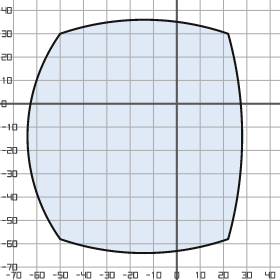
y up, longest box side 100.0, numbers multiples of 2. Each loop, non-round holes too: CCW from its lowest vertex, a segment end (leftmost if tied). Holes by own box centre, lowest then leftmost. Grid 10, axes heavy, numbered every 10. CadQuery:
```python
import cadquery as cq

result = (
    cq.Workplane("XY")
    .moveTo(-50.0, -58.0)
    .threePointArc((-14.0, -64.0), (22.0, -58.0))
    .threePointArc((28.0, -14.0), (22.0, 30.0))
    .threePointArc((-14.0, 36.0), (-50.0, 30.0))
    .threePointArc((-64.0, -14.0), (-50.0, -58.0))
    .close()
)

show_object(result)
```